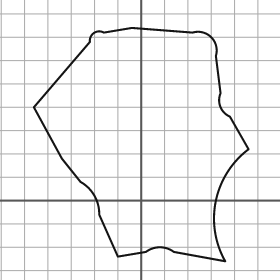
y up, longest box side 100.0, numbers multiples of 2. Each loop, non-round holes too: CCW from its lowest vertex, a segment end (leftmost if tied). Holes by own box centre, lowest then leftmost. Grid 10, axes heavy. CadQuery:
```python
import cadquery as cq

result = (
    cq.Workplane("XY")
    .moveTo(36.0, -26.0)
    .threePointArc((32.0, 0.0), (46.0, 22.0))
    .lineTo(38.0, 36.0)
    .threePointArc((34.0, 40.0), (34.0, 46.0))
    .lineTo(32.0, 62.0)
    .threePointArc((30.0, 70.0), (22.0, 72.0))
    .lineTo(-4.0, 74.0)
    .lineTo(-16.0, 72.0)
    .threePointArc((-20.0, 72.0), (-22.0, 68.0))
    .lineTo(-46.0, 40.0)
    .lineTo(-34.0, 18.0)
    .lineTo(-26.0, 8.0)
    .threePointArc((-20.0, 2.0), (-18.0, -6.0))
    .lineTo(-10.0, -24.0)
    .lineTo(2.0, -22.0)
    .threePointArc((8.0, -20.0), (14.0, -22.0))
    .close()
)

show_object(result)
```